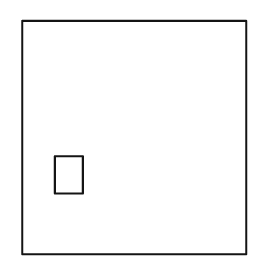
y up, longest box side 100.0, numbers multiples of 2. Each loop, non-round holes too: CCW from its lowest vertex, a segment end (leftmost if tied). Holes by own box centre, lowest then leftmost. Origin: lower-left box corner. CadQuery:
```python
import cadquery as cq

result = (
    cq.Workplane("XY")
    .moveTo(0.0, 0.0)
    .lineTo(96.0, 0.0)
    .lineTo(96.0, 100.0)
    .lineTo(0.0, 100.0)
    .close()
    .moveTo(14.0, 26.0)
    .lineTo(26.0, 26.0)
    .lineTo(26.0, 42.0)
    .lineTo(14.0, 42.0)
    .close()
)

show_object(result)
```